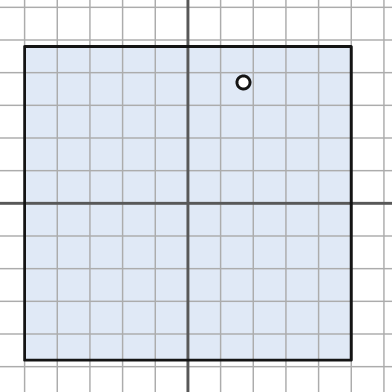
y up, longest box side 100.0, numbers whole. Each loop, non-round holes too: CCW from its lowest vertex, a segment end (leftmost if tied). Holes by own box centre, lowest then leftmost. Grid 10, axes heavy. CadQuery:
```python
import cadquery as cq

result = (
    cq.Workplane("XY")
    .moveTo(-50.0, -48.0)
    .lineTo(50.0, -48.0)
    .lineTo(50.0, 48.0)
    .lineTo(-50.0, 48.0)
    .close()
    .moveTo(17.0, 37.0)
    .circle(2.0)
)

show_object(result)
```